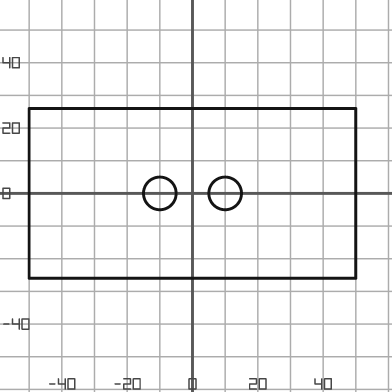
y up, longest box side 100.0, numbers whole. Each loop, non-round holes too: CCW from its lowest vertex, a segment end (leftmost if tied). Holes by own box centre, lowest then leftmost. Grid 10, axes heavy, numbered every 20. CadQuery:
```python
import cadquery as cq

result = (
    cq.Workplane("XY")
    .moveTo(-50.0, -26.0)
    .lineTo(50.0, -26.0)
    .lineTo(50.0, 26.0)
    .lineTo(-50.0, 26.0)
    .close()
    .moveTo(-10.0, 0.0)
    .circle(5.0)
    .moveTo(10.0, 0.0)
    .circle(5.0)
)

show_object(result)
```